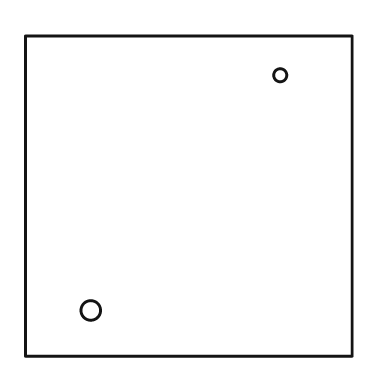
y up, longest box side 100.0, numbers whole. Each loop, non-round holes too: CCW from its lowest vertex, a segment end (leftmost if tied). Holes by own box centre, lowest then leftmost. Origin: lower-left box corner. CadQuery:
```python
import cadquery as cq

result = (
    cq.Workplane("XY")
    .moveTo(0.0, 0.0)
    .lineTo(100.0, 0.0)
    .lineTo(100.0, 98.0)
    .lineTo(0.0, 98.0)
    .close()
    .moveTo(20.0, 14.0)
    .circle(3.0)
    .moveTo(78.0, 86.0)
    .circle(2.0)
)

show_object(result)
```